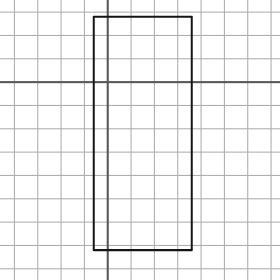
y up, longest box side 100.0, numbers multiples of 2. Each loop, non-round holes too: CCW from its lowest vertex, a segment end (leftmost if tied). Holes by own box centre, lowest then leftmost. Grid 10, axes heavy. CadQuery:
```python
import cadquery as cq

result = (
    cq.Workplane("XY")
    .moveTo(-6.0, -72.0)
    .lineTo(36.0, -72.0)
    .lineTo(36.0, 28.0)
    .lineTo(-6.0, 28.0)
    .close()
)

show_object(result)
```